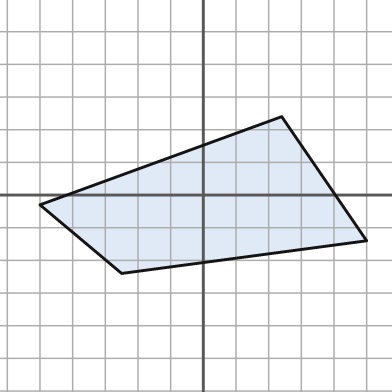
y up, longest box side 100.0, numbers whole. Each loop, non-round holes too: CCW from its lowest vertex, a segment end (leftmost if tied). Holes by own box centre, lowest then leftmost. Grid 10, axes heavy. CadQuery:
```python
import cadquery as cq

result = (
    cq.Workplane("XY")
    .moveTo(-25.0, -24.0)
    .lineTo(50.0, -14.0)
    .lineTo(24.0, 24.0)
    .lineTo(-50.0, -3.0)
    .close()
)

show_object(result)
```